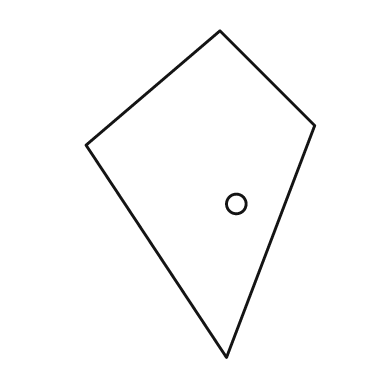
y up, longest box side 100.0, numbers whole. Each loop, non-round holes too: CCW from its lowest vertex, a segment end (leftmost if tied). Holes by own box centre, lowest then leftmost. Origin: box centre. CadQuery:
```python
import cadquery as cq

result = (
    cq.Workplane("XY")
    .moveTo(8.0, -50.0)
    .lineTo(35.0, 21.0)
    .lineTo(6.0, 50.0)
    .lineTo(-35.0, 15.0)
    .close()
    .moveTo(11.0, -3.0)
    .circle(3.0)
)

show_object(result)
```